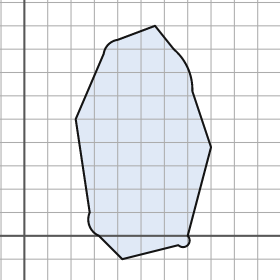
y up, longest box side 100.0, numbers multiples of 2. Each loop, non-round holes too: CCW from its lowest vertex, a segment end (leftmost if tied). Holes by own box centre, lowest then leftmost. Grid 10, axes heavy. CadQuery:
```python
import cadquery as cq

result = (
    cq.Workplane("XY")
    .moveTo(42.0, -10.0)
    .lineTo(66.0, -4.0)
    .threePointArc((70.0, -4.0), (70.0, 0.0))
    .lineTo(80.0, 38.0)
    .lineTo(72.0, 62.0)
    .threePointArc((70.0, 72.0), (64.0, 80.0))
    .lineTo(56.0, 90.0)
    .lineTo(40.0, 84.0)
    .threePointArc((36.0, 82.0), (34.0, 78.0))
    .lineTo(22.0, 50.0)
    .lineTo(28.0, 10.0)
    .threePointArc((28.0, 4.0), (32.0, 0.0))
    .close()
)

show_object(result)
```